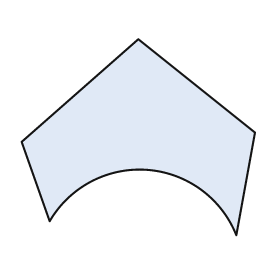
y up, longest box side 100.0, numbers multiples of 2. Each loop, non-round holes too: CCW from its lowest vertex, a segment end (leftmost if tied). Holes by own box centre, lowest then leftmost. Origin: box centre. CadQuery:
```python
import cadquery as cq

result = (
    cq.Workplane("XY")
    .moveTo(42.0, -42.0)
    .lineTo(50.0, 2.0)
    .lineTo(0.0, 42.0)
    .lineTo(-50.0, -2.0)
    .lineTo(-38.0, -36.0)
    .threePointArc((4.0, -14.0), (42.0, -42.0))
    .close()
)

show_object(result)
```